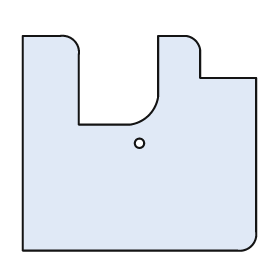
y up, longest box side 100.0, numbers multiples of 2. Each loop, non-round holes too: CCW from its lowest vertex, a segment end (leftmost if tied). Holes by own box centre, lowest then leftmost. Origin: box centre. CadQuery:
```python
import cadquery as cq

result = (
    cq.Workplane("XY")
    .moveTo(-50.0, -46.0)
    .lineTo(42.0, -46.0)
    .threePointArc((48.0, -44.0), (50.0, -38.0))
    .lineTo(50.0, 28.0)
    .lineTo(26.0, 28.0)
    .lineTo(26.0, 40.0)
    .threePointArc((24.0, 44.0), (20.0, 46.0))
    .lineTo(8.0, 46.0)
    .lineTo(8.0, 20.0)
    .threePointArc((4.0, 12.0), (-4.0, 8.0))
    .lineTo(-26.0, 8.0)
    .lineTo(-26.0, 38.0)
    .threePointArc((-28.0, 44.0), (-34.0, 46.0))
    .lineTo(-50.0, 46.0)
    .close()
    .moveTo(0.0, 0.0)
    .circle(2.0)
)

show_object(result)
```